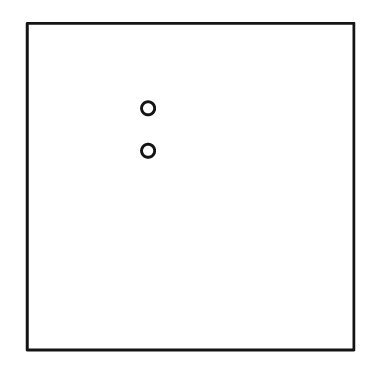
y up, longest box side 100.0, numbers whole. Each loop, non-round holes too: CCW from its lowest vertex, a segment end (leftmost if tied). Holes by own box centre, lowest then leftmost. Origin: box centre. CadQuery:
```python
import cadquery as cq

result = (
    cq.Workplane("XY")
    .moveTo(-50.0, -50.0)
    .lineTo(50.0, -50.0)
    .lineTo(50.0, 50.0)
    .lineTo(-50.0, 50.0)
    .close()
    .moveTo(-13.0, 11.0)
    .circle(2.0)
    .moveTo(-13.0, 24.0)
    .circle(2.0)
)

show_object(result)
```